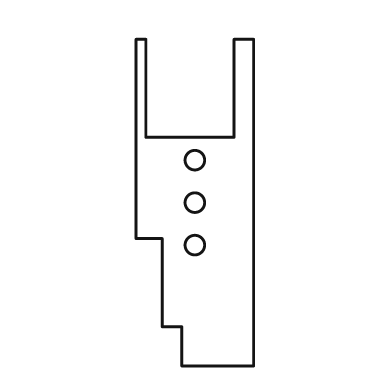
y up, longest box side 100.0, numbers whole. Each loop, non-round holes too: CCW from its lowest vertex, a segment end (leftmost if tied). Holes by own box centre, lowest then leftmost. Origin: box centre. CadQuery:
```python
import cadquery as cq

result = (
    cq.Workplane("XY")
    .moveTo(-4.0, -50.0)
    .lineTo(18.0, -50.0)
    .lineTo(18.0, 50.0)
    .lineTo(12.0, 50.0)
    .lineTo(12.0, 20.0)
    .lineTo(-15.0, 20.0)
    .lineTo(-15.0, 50.0)
    .lineTo(-18.0, 50.0)
    .lineTo(-18.0, -11.0)
    .lineTo(-10.0, -11.0)
    .lineTo(-10.0, -38.0)
    .lineTo(-4.0, -38.0)
    .close()
    .moveTo(0.0, -13.0)
    .circle(3.0)
    .moveTo(0.0, 0.0)
    .circle(3.0)
    .moveTo(0.0, 13.0)
    .circle(3.0)
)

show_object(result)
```